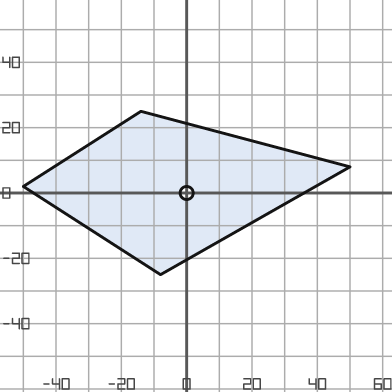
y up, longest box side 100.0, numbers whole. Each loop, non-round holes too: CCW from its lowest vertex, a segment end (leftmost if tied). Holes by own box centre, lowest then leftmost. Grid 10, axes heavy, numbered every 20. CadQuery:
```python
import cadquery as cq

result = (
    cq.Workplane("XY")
    .moveTo(-8.0, -25.0)
    .lineTo(50.0, 8.0)
    .lineTo(-14.0, 25.0)
    .lineTo(-50.0, 2.0)
    .close()
    .moveTo(0.0, 0.0)
    .circle(2.0)
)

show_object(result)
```